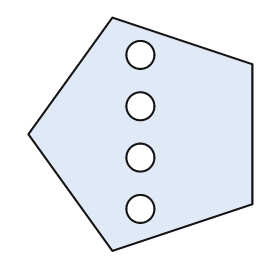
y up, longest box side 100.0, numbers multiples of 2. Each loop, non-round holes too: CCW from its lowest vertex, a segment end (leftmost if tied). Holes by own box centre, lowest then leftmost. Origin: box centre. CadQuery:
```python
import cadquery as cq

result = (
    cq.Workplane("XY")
    .moveTo(-12.0, -50.0)
    .lineTo(48.0, -30.0)
    .lineTo(48.0, 30.0)
    .lineTo(-12.0, 50.0)
    .lineTo(-48.0, 0.0)
    .close()
    .moveTo(0.0, -32.0)
    .circle(6.0)
    .moveTo(0.0, -10.0)
    .circle(6.0)
    .moveTo(0.0, 12.0)
    .circle(6.0)
    .moveTo(0.0, 34.0)
    .circle(6.0)
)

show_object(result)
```